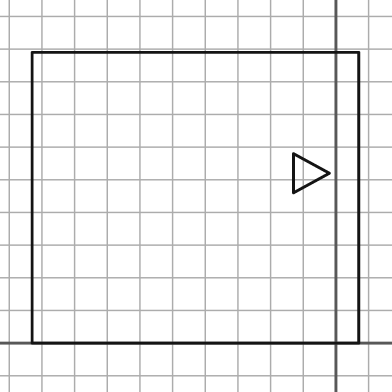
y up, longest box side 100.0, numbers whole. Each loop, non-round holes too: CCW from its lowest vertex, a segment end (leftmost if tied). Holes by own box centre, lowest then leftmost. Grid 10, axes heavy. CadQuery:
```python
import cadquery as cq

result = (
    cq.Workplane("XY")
    .moveTo(-93.0, 0.0)
    .lineTo(7.0, 0.0)
    .lineTo(7.0, 89.0)
    .lineTo(-93.0, 89.0)
    .close()
    .moveTo(-13.0, 46.0)
    .lineTo(-2.0, 52.0)
    .lineTo(-13.0, 58.0)
    .close()
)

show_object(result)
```